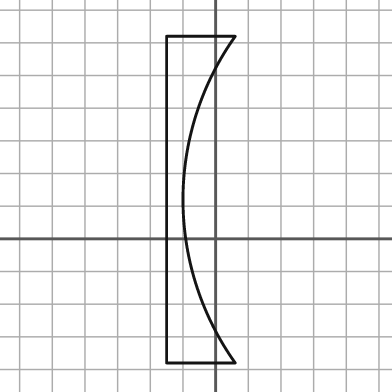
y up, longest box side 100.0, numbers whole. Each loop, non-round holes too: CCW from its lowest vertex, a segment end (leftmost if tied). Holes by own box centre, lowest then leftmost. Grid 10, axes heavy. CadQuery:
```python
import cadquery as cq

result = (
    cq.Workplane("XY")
    .moveTo(-15.0, -38.0)
    .lineTo(6.0, -38.0)
    .threePointArc((-10.0, 12.0), (6.0, 62.0))
    .lineTo(-15.0, 62.0)
    .close()
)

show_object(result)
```